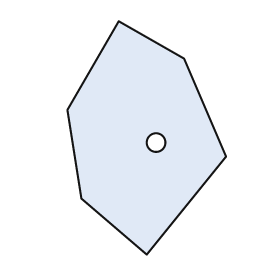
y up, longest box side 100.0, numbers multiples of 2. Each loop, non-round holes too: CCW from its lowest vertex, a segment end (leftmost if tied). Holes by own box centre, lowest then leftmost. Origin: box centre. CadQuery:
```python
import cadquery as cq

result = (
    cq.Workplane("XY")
    .moveTo(0.0, -50.0)
    .lineTo(34.0, -8.0)
    .lineTo(16.0, 34.0)
    .lineTo(-12.0, 50.0)
    .lineTo(-34.0, 12.0)
    .lineTo(-28.0, -26.0)
    .close()
    .moveTo(4.0, -2.0)
    .circle(4.0)
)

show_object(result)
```